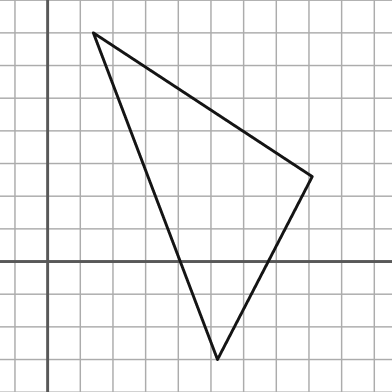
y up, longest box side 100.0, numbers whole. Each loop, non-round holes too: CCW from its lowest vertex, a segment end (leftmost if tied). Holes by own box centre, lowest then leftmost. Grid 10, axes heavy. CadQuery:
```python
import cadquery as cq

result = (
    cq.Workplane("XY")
    .moveTo(52.0, -30.0)
    .lineTo(81.0, 26.0)
    .lineTo(14.0, 70.0)
    .close()
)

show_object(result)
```